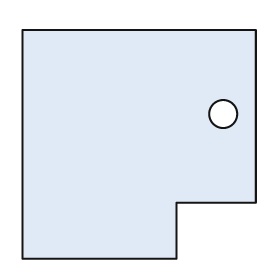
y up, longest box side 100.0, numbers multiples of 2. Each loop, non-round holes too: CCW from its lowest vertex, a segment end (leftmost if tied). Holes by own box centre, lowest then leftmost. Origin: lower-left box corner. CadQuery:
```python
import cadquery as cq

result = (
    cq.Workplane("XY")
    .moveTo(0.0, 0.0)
    .lineTo(66.0, 0.0)
    .lineTo(66.0, 24.0)
    .lineTo(100.0, 24.0)
    .lineTo(100.0, 98.0)
    .lineTo(0.0, 98.0)
    .close()
    .moveTo(86.0, 62.0)
    .circle(6.0)
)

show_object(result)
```